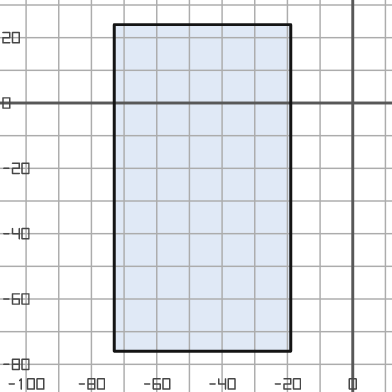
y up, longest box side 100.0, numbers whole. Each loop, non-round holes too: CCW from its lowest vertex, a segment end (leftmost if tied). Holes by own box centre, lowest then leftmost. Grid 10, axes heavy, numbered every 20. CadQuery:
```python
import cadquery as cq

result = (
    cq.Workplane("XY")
    .moveTo(-73.0, -76.0)
    .lineTo(-19.0, -76.0)
    .lineTo(-19.0, 24.0)
    .lineTo(-73.0, 24.0)
    .close()
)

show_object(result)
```